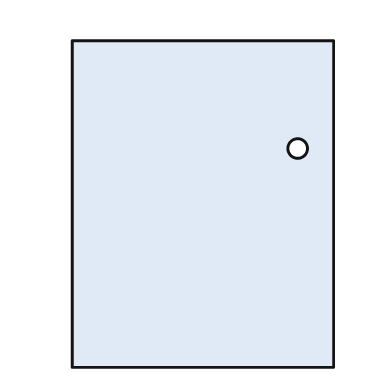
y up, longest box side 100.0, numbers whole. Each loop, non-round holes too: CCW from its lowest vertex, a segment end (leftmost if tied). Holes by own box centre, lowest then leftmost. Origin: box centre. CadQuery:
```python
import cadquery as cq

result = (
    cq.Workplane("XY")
    .moveTo(-40.0, -50.0)
    .lineTo(40.0, -50.0)
    .lineTo(40.0, 50.0)
    .lineTo(-40.0, 50.0)
    .close()
    .moveTo(29.0, 17.0)
    .circle(3.0)
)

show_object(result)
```